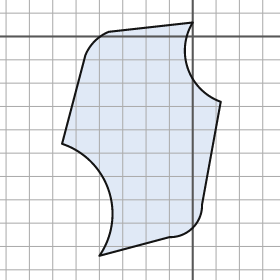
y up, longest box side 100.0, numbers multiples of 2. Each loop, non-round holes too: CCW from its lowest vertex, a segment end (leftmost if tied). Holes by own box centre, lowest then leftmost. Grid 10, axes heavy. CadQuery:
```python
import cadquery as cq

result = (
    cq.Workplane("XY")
    .moveTo(-40.0, -94.0)
    .lineTo(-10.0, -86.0)
    .threePointArc((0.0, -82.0), (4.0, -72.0))
    .lineTo(12.0, -28.0)
    .threePointArc((-2.0, -14.0), (0.0, 6.0))
    .lineTo(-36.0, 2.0)
    .threePointArc((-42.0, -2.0), (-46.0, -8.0))
    .lineTo(-56.0, -46.0)
    .threePointArc((-36.0, -66.0), (-40.0, -94.0))
    .close()
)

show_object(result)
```